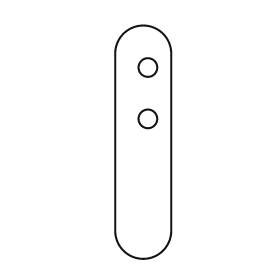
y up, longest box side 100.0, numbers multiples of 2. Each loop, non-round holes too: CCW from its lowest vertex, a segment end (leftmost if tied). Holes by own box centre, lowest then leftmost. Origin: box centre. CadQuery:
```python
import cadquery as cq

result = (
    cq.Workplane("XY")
    .moveTo(-12.0, -38.0)
    .threePointArc((0.0, -50.0), (12.0, -38.0))
    .lineTo(12.0, 38.0)
    .threePointArc((0.0, 50.0), (-12.0, 38.0))
    .close()
    .moveTo(2.0, 10.0)
    .circle(4.0)
    .moveTo(2.0, 32.0)
    .circle(4.0)
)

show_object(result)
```